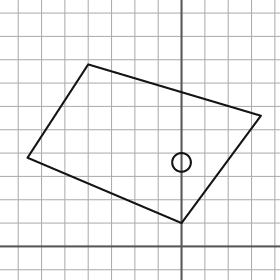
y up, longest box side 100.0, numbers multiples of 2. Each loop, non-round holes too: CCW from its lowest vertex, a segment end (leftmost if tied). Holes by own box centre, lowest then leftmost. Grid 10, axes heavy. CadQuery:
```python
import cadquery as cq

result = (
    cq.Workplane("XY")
    .moveTo(0.0, 10.0)
    .lineTo(34.0, 56.0)
    .lineTo(-40.0, 78.0)
    .lineTo(-66.0, 38.0)
    .close()
    .moveTo(0.0, 36.0)
    .circle(4.0)
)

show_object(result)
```